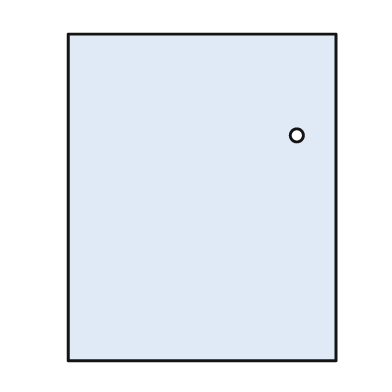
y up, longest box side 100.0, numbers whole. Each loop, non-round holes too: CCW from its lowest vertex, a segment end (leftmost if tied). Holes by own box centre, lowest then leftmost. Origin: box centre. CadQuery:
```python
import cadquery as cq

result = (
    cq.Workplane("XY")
    .moveTo(-41.0, -50.0)
    .lineTo(41.0, -50.0)
    .lineTo(41.0, 50.0)
    .lineTo(-41.0, 50.0)
    .close()
    .moveTo(29.0, 19.0)
    .circle(2.0)
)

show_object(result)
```